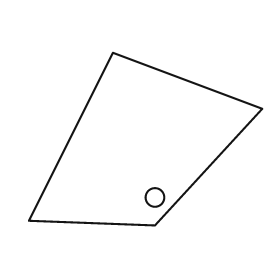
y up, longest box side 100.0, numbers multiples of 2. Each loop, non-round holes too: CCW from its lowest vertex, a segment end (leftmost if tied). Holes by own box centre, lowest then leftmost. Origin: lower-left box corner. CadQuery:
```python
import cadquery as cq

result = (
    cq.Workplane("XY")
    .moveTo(54.0, 0.0)
    .lineTo(100.0, 50.0)
    .lineTo(36.0, 74.0)
    .lineTo(0.0, 2.0)
    .close()
    .moveTo(54.0, 12.0)
    .circle(4.0)
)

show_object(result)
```